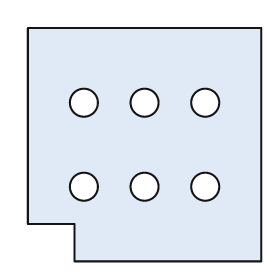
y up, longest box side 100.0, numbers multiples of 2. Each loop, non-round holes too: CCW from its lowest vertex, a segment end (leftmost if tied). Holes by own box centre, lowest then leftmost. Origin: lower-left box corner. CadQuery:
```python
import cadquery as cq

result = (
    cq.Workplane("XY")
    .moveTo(20.0, 0.0)
    .lineTo(100.0, 0.0)
    .lineTo(100.0, 100.0)
    .lineTo(0.0, 100.0)
    .lineTo(0.0, 16.0)
    .lineTo(20.0, 16.0)
    .close()
    .moveTo(24.0, 32.0)
    .circle(6.0)
    .moveTo(50.0, 32.0)
    .circle(6.0)
    .moveTo(76.0, 32.0)
    .circle(6.0)
    .moveTo(24.0, 68.0)
    .circle(6.0)
    .moveTo(50.0, 68.0)
    .circle(6.0)
    .moveTo(76.0, 68.0)
    .circle(6.0)
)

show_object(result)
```